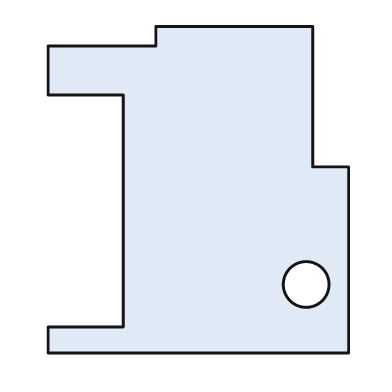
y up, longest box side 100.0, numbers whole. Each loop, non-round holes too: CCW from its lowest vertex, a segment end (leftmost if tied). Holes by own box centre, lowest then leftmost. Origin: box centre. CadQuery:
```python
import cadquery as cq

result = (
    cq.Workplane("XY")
    .moveTo(-46.0, -50.0)
    .lineTo(46.0, -50.0)
    .lineTo(46.0, 7.0)
    .lineTo(35.0, 7.0)
    .lineTo(35.0, 50.0)
    .lineTo(-13.0, 50.0)
    .lineTo(-13.0, 44.0)
    .lineTo(-46.0, 44.0)
    .lineTo(-46.0, 29.0)
    .lineTo(-23.0, 29.0)
    .lineTo(-23.0, -42.0)
    .lineTo(-46.0, -42.0)
    .close()
    .moveTo(33.0, -29.0)
    .circle(7.0)
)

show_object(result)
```